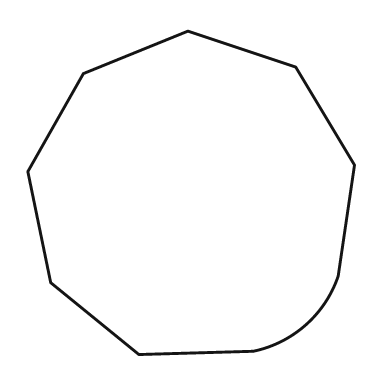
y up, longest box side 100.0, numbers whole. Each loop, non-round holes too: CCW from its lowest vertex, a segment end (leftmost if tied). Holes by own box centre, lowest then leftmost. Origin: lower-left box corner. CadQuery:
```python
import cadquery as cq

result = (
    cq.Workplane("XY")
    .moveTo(34.0, 0.0)
    .lineTo(69.0, 1.0)
    .threePointArc((85.0, 9.0), (95.0, 24.0))
    .lineTo(100.0, 58.0)
    .lineTo(82.0, 88.0)
    .lineTo(49.0, 99.0)
    .lineTo(17.0, 86.0)
    .lineTo(0.0, 56.0)
    .lineTo(7.0, 22.0)
    .close()
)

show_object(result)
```